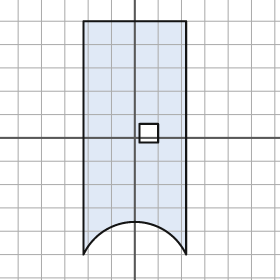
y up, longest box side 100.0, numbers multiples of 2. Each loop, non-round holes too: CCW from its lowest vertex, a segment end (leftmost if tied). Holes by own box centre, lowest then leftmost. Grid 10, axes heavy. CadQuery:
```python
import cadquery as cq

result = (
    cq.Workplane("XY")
    .moveTo(-22.0, -50.0)
    .threePointArc((0.0, -36.0), (22.0, -50.0))
    .lineTo(22.0, 50.0)
    .lineTo(-22.0, 50.0)
    .close()
    .moveTo(2.0, -2.0)
    .lineTo(10.0, -2.0)
    .lineTo(10.0, 6.0)
    .lineTo(2.0, 6.0)
    .close()
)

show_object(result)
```